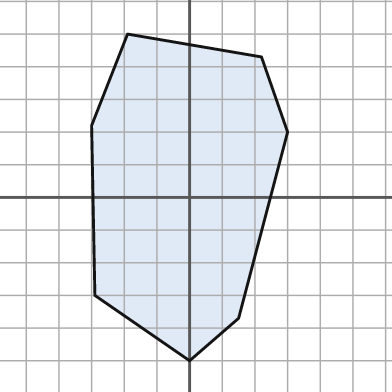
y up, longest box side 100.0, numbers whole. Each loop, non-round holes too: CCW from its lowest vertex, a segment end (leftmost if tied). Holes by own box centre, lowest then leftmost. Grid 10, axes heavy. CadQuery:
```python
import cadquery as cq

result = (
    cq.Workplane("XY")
    .moveTo(0.0, -50.0)
    .lineTo(15.0, -37.0)
    .lineTo(30.0, 20.0)
    .lineTo(22.0, 43.0)
    .lineTo(-19.0, 50.0)
    .lineTo(-30.0, 22.0)
    .lineTo(-29.0, -30.0)
    .close()
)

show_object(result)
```